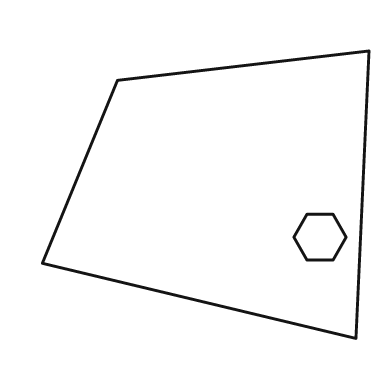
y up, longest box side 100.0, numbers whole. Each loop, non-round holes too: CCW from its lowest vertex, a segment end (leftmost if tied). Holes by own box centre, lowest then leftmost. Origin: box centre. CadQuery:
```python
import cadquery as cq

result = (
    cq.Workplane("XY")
    .moveTo(46.0, -44.0)
    .lineTo(50.0, 44.0)
    .lineTo(-27.0, 35.0)
    .lineTo(-50.0, -21.0)
    .close()
    .moveTo(31.0, -20.0)
    .lineTo(39.0, -20.0)
    .lineTo(43.0, -13.0)
    .lineTo(39.0, -6.0)
    .lineTo(31.0, -6.0)
    .lineTo(27.0, -13.0)
    .close()
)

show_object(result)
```